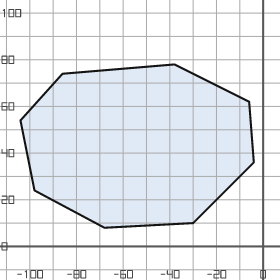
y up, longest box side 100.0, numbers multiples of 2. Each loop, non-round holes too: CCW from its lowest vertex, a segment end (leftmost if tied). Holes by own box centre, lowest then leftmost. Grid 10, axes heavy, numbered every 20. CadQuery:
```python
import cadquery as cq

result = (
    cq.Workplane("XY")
    .moveTo(-68.0, 8.0)
    .lineTo(-30.0, 10.0)
    .lineTo(-4.0, 36.0)
    .lineTo(-6.0, 62.0)
    .lineTo(-38.0, 78.0)
    .lineTo(-86.0, 74.0)
    .lineTo(-104.0, 54.0)
    .lineTo(-98.0, 24.0)
    .close()
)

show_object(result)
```